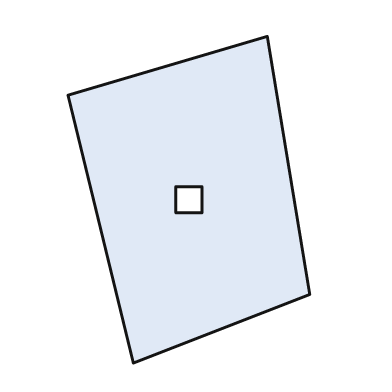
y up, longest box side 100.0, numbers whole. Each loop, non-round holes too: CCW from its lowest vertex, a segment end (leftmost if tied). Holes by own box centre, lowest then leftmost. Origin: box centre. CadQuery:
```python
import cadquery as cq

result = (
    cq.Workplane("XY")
    .moveTo(-17.0, -50.0)
    .lineTo(37.0, -29.0)
    .lineTo(24.0, 50.0)
    .lineTo(-37.0, 32.0)
    .close()
    .moveTo(-4.0, -4.0)
    .lineTo(4.0, -4.0)
    .lineTo(4.0, 4.0)
    .lineTo(-4.0, 4.0)
    .close()
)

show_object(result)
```